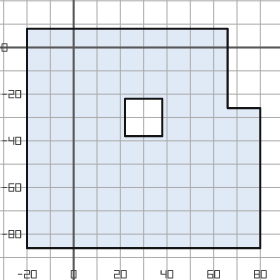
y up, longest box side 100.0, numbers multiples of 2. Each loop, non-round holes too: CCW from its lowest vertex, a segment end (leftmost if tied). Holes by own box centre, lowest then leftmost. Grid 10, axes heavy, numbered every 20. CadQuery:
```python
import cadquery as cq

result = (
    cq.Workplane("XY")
    .moveTo(-20.0, -86.0)
    .lineTo(80.0, -86.0)
    .lineTo(80.0, -26.0)
    .lineTo(66.0, -26.0)
    .lineTo(66.0, 8.0)
    .lineTo(-20.0, 8.0)
    .close()
    .moveTo(22.0, -38.0)
    .lineTo(38.0, -38.0)
    .lineTo(38.0, -22.0)
    .lineTo(22.0, -22.0)
    .close()
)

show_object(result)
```